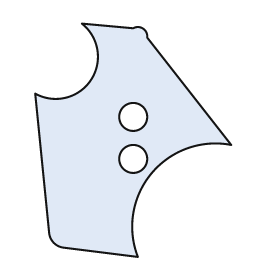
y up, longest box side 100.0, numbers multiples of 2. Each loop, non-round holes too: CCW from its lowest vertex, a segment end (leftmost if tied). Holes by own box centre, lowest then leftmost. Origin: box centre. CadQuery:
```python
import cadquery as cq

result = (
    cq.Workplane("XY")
    .moveTo(2.0, -50.0)
    .threePointArc((8.0, -14.0), (42.0, -2.0))
    .lineTo(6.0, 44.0)
    .threePointArc((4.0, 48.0), (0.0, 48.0))
    .lineTo(-22.0, 50.0)
    .threePointArc((-18.0, 26.0), (-42.0, 20.0))
    .lineTo(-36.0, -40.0)
    .threePointArc((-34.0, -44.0), (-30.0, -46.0))
    .close()
    .moveTo(0.0, -8.0)
    .circle(6.0)
    .moveTo(0.0, 10.0)
    .circle(6.0)
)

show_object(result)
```